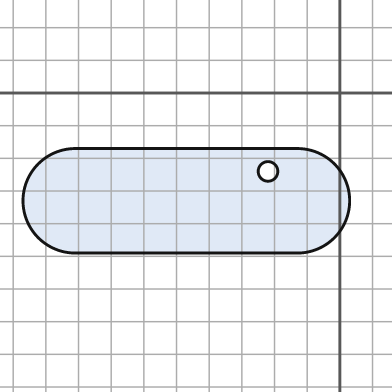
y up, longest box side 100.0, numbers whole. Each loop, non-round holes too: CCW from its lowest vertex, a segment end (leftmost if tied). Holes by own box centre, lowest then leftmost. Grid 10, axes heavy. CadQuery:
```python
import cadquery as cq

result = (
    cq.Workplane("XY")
    .moveTo(-81.0, -49.0)
    .lineTo(-13.0, -49.0)
    .threePointArc((3.0, -33.0), (-13.0, -17.0))
    .lineTo(-81.0, -17.0)
    .threePointArc((-97.0, -33.0), (-81.0, -49.0))
    .close()
    .moveTo(-22.0, -24.0)
    .circle(3.0)
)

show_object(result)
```